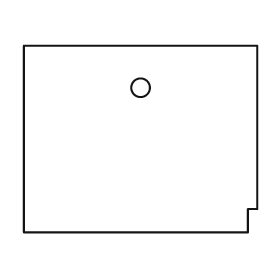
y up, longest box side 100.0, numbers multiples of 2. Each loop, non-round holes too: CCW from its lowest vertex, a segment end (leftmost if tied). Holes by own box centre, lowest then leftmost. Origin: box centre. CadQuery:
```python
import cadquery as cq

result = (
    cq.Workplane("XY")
    .moveTo(-50.0, -40.0)
    .lineTo(46.0, -40.0)
    .lineTo(46.0, -30.0)
    .lineTo(50.0, -30.0)
    .lineTo(50.0, 40.0)
    .lineTo(-50.0, 40.0)
    .close()
    .moveTo(0.0, 22.0)
    .circle(4.0)
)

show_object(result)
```